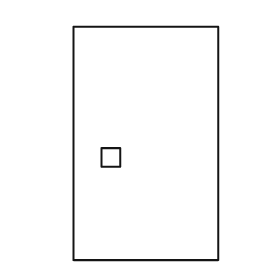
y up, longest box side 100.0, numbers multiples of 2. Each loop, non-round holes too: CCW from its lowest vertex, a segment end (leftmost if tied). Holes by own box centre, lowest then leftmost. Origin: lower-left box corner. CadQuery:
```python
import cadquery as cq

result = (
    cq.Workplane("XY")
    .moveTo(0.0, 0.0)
    .lineTo(62.0, 0.0)
    .lineTo(62.0, 100.0)
    .lineTo(0.0, 100.0)
    .close()
    .moveTo(12.0, 40.0)
    .lineTo(20.0, 40.0)
    .lineTo(20.0, 48.0)
    .lineTo(12.0, 48.0)
    .close()
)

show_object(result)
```